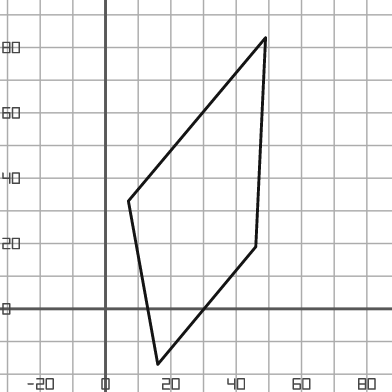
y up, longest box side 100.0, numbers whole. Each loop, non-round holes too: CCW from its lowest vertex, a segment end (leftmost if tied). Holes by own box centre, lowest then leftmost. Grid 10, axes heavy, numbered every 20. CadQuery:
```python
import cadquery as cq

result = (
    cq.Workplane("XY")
    .moveTo(16.0, -17.0)
    .lineTo(46.0, 19.0)
    .lineTo(49.0, 83.0)
    .lineTo(7.0, 33.0)
    .close()
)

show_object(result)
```